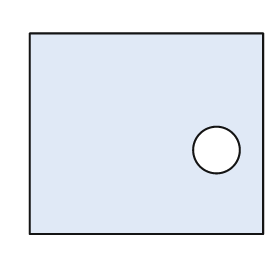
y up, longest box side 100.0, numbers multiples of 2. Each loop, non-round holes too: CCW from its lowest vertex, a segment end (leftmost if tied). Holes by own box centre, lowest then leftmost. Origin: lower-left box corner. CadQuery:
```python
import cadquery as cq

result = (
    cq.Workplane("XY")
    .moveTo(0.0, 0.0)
    .lineTo(100.0, 0.0)
    .lineTo(100.0, 86.0)
    .lineTo(0.0, 86.0)
    .close()
    .moveTo(80.0, 36.0)
    .circle(10.0)
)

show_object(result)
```